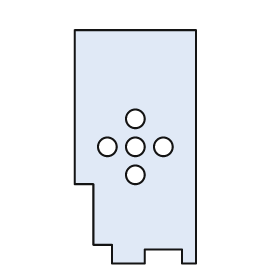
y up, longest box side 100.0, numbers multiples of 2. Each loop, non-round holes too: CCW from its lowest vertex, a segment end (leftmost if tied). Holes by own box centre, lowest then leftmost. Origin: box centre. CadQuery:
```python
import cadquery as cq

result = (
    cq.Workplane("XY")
    .moveTo(-10.0, -50.0)
    .lineTo(4.0, -50.0)
    .lineTo(4.0, -44.0)
    .lineTo(20.0, -44.0)
    .lineTo(20.0, -50.0)
    .lineTo(26.0, -50.0)
    .lineTo(26.0, 50.0)
    .lineTo(-26.0, 50.0)
    .lineTo(-26.0, -16.0)
    .lineTo(-18.0, -16.0)
    .lineTo(-18.0, -42.0)
    .lineTo(-10.0, -42.0)
    .close()
    .moveTo(0.0, -12.0)
    .circle(4.0)
    .moveTo(-12.0, 0.0)
    .circle(4.0)
    .moveTo(0.0, 0.0)
    .circle(4.0)
    .moveTo(12.0, 0.0)
    .circle(4.0)
    .moveTo(0.0, 12.0)
    .circle(4.0)
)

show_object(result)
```